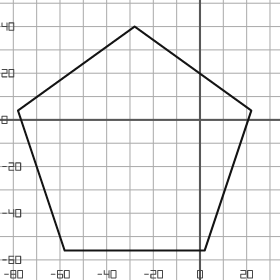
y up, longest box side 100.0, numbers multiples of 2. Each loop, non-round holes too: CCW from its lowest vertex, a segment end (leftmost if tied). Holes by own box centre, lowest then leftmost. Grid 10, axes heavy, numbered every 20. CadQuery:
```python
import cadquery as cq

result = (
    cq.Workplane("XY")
    .moveTo(-58.0, -56.0)
    .lineTo(2.0, -56.0)
    .lineTo(22.0, 4.0)
    .lineTo(-28.0, 40.0)
    .lineTo(-78.0, 4.0)
    .close()
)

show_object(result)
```